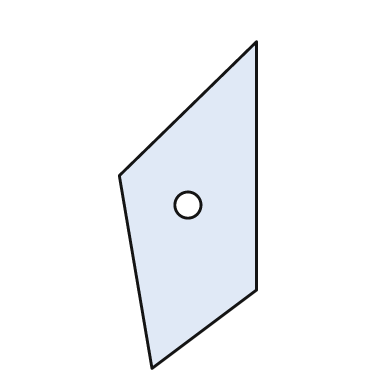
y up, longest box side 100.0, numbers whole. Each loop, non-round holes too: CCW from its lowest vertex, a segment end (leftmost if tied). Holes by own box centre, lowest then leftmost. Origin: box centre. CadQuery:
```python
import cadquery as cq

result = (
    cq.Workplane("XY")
    .moveTo(-11.0, -50.0)
    .lineTo(21.0, -26.0)
    .lineTo(21.0, 50.0)
    .lineTo(-21.0, 9.0)
    .close()
    .moveTo(0.0, 0.0)
    .circle(4.0)
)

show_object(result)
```